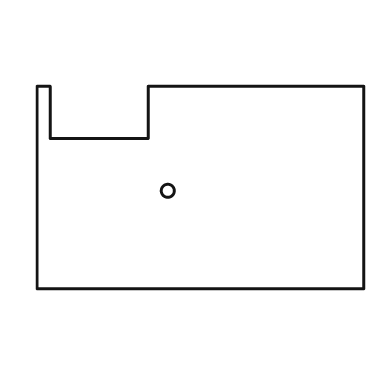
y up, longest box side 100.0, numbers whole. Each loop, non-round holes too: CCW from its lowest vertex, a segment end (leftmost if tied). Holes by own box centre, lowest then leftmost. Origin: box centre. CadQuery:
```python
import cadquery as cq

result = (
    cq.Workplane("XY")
    .moveTo(-50.0, -31.0)
    .lineTo(50.0, -31.0)
    .lineTo(50.0, 31.0)
    .lineTo(-16.0, 31.0)
    .lineTo(-16.0, 15.0)
    .lineTo(-46.0, 15.0)
    .lineTo(-46.0, 31.0)
    .lineTo(-50.0, 31.0)
    .close()
    .moveTo(-10.0, -1.0)
    .circle(2.0)
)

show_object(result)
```